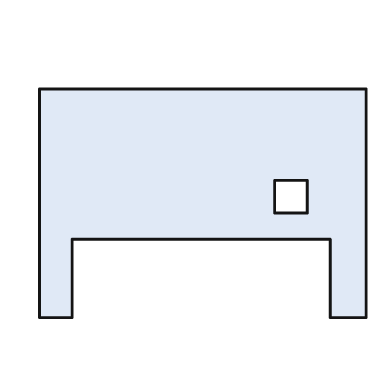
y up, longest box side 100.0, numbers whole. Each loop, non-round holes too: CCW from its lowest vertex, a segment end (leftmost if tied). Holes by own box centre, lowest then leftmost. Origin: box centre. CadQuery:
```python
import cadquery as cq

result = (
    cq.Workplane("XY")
    .moveTo(-50.0, -35.0)
    .lineTo(-40.0, -35.0)
    .lineTo(-40.0, -11.0)
    .lineTo(39.0, -11.0)
    .lineTo(39.0, -35.0)
    .lineTo(50.0, -35.0)
    .lineTo(50.0, 35.0)
    .lineTo(-50.0, 35.0)
    .close()
    .moveTo(22.0, -3.0)
    .lineTo(32.0, -3.0)
    .lineTo(32.0, 7.0)
    .lineTo(22.0, 7.0)
    .close()
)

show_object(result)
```